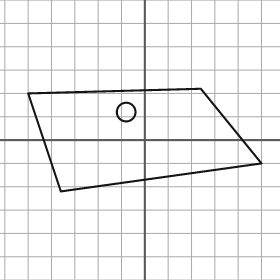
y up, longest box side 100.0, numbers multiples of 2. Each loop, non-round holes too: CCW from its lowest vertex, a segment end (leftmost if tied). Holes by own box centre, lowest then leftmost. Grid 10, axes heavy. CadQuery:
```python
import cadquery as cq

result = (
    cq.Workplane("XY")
    .moveTo(-36.0, -22.0)
    .lineTo(50.0, -10.0)
    .lineTo(24.0, 22.0)
    .lineTo(-50.0, 20.0)
    .close()
    .moveTo(-8.0, 12.0)
    .circle(4.0)
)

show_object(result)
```